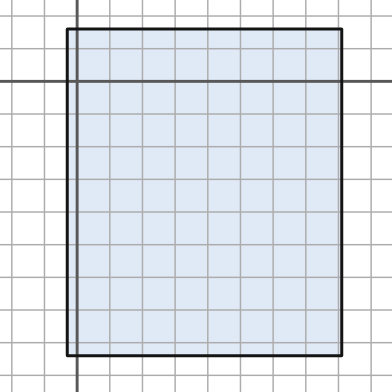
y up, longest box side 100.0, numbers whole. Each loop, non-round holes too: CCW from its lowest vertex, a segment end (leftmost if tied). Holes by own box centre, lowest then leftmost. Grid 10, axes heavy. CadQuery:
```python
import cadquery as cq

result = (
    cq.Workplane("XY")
    .moveTo(-3.0, -84.0)
    .lineTo(81.0, -84.0)
    .lineTo(81.0, 16.0)
    .lineTo(-3.0, 16.0)
    .close()
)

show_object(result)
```